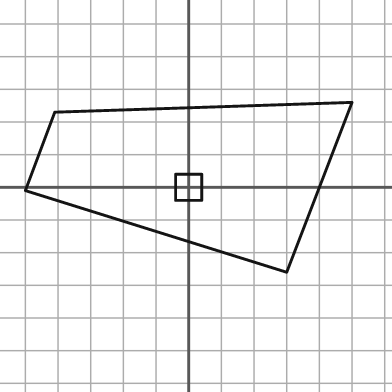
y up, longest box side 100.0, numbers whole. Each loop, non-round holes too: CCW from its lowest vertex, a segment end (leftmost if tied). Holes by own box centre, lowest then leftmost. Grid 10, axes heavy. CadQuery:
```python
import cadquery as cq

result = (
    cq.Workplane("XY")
    .moveTo(30.0, -26.0)
    .lineTo(50.0, 26.0)
    .lineTo(-41.0, 23.0)
    .lineTo(-50.0, -1.0)
    .close()
    .moveTo(-4.0, -4.0)
    .lineTo(4.0, -4.0)
    .lineTo(4.0, 4.0)
    .lineTo(-4.0, 4.0)
    .close()
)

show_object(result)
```